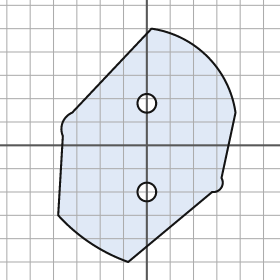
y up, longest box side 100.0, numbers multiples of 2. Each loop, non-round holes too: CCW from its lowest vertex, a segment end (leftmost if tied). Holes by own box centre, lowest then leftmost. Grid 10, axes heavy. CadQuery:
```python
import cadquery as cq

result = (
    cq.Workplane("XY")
    .moveTo(-8.0, -50.0)
    .lineTo(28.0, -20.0)
    .threePointArc((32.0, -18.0), (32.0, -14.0))
    .lineTo(38.0, 14.0)
    .threePointArc((26.0, 38.0), (2.0, 50.0))
    .lineTo(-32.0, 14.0)
    .threePointArc((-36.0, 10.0), (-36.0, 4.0))
    .lineTo(-38.0, -30.0)
    .threePointArc((-24.0, -42.0), (-8.0, -50.0))
    .close()
    .moveTo(0.0, -20.0)
    .circle(4.0)
    .moveTo(0.0, 18.0)
    .circle(4.0)
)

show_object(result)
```